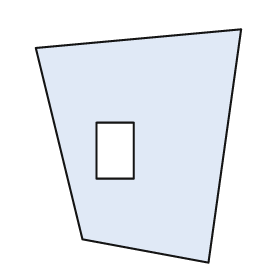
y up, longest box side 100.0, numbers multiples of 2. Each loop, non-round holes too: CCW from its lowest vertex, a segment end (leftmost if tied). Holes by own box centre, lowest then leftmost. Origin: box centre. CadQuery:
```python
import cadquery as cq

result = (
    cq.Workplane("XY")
    .moveTo(30.0, -50.0)
    .lineTo(44.0, 50.0)
    .lineTo(-44.0, 42.0)
    .lineTo(-24.0, -40.0)
    .close()
    .moveTo(-18.0, -14.0)
    .lineTo(-2.0, -14.0)
    .lineTo(-2.0, 10.0)
    .lineTo(-18.0, 10.0)
    .close()
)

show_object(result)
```